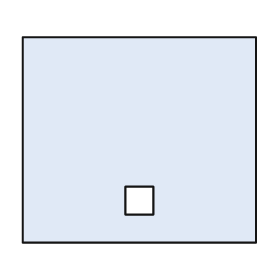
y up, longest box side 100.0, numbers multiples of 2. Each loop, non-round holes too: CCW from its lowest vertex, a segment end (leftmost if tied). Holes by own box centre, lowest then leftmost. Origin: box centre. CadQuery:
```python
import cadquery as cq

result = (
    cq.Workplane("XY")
    .moveTo(-50.0, -44.0)
    .lineTo(50.0, -44.0)
    .lineTo(50.0, 44.0)
    .lineTo(-50.0, 44.0)
    .close()
    .moveTo(-6.0, -32.0)
    .lineTo(6.0, -32.0)
    .lineTo(6.0, -20.0)
    .lineTo(-6.0, -20.0)
    .close()
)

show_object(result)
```